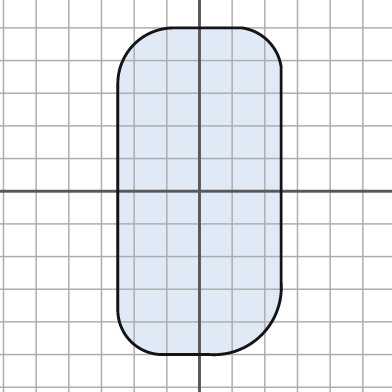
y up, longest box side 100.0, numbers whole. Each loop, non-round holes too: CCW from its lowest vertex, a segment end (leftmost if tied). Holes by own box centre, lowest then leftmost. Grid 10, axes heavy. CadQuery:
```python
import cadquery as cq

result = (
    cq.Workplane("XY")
    .moveTo(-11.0, -50.0)
    .lineTo(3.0, -50.0)
    .threePointArc((19.0, -44.0), (25.0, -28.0))
    .lineTo(25.0, 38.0)
    .threePointArc((21.0, 46.0), (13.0, 50.0))
    .lineTo(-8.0, 50.0)
    .threePointArc((-20.0, 45.0), (-25.0, 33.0))
    .lineTo(-25.0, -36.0)
    .threePointArc((-21.0, -46.0), (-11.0, -50.0))
    .close()
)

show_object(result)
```